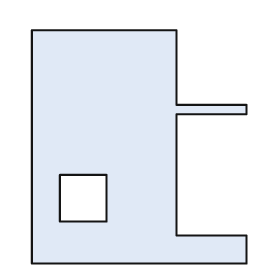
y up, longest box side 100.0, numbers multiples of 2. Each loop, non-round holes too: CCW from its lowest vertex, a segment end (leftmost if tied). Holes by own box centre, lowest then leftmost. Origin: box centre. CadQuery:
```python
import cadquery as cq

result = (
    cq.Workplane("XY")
    .moveTo(-46.0, -50.0)
    .lineTo(46.0, -50.0)
    .lineTo(46.0, -38.0)
    .lineTo(16.0, -38.0)
    .lineTo(16.0, 14.0)
    .lineTo(46.0, 14.0)
    .lineTo(46.0, 18.0)
    .lineTo(16.0, 18.0)
    .lineTo(16.0, 50.0)
    .lineTo(-46.0, 50.0)
    .close()
    .moveTo(-34.0, -32.0)
    .lineTo(-14.0, -32.0)
    .lineTo(-14.0, -12.0)
    .lineTo(-34.0, -12.0)
    .close()
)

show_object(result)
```